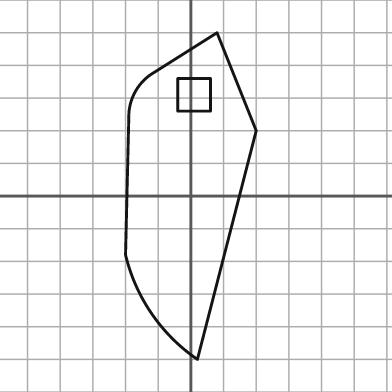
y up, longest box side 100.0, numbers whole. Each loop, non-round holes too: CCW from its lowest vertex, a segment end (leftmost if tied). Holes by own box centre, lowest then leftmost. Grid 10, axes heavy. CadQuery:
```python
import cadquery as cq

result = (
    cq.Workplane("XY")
    .moveTo(2.0, -50.0)
    .lineTo(20.0, 20.0)
    .lineTo(8.0, 50.0)
    .lineTo(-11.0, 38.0)
    .threePointArc((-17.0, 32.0), (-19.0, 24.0))
    .lineTo(-20.0, -18.0)
    .threePointArc((-12.0, -36.0), (2.0, -50.0))
    .close()
    .moveTo(-4.0, 26.0)
    .lineTo(6.0, 26.0)
    .lineTo(6.0, 36.0)
    .lineTo(-4.0, 36.0)
    .close()
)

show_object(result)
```